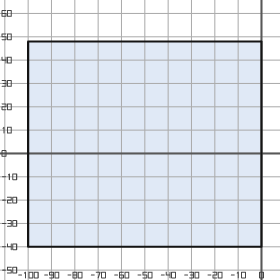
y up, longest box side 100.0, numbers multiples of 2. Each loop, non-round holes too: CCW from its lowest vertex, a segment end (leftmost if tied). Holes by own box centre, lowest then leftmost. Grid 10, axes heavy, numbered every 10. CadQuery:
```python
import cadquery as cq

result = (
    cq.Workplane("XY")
    .moveTo(-100.0, -40.0)
    .lineTo(0.0, -40.0)
    .lineTo(0.0, 48.0)
    .lineTo(-100.0, 48.0)
    .close()
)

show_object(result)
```